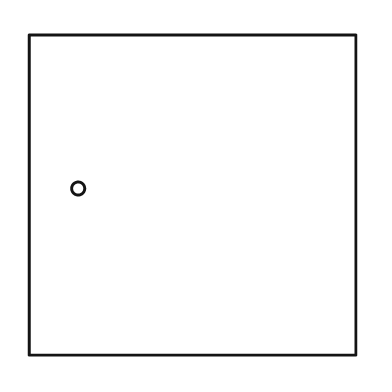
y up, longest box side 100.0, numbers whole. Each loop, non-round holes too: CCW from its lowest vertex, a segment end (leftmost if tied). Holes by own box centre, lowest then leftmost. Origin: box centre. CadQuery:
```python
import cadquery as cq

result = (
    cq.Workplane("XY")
    .moveTo(-50.0, -49.0)
    .lineTo(50.0, -49.0)
    .lineTo(50.0, 49.0)
    .lineTo(-50.0, 49.0)
    .close()
    .moveTo(-35.0, 2.0)
    .circle(2.0)
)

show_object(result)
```